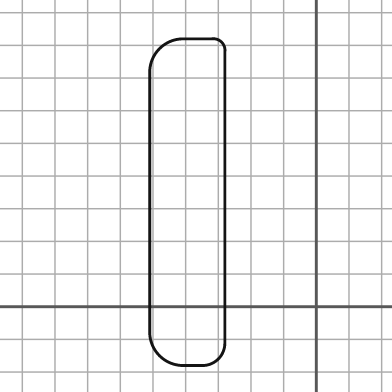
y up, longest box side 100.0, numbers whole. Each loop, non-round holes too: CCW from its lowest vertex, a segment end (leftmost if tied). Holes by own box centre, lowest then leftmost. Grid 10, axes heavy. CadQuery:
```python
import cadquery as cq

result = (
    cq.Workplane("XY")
    .moveTo(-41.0, -18.0)
    .lineTo(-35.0, -18.0)
    .threePointArc((-30.0, -16.0), (-28.0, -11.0))
    .lineTo(-28.0, 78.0)
    .threePointArc((-29.0, 81.0), (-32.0, 82.0))
    .lineTo(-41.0, 82.0)
    .threePointArc((-48.0, 79.0), (-51.0, 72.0))
    .lineTo(-51.0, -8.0)
    .threePointArc((-48.0, -15.0), (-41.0, -18.0))
    .close()
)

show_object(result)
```